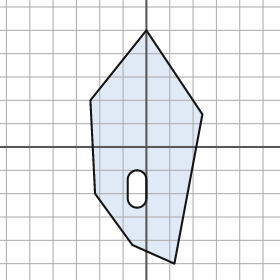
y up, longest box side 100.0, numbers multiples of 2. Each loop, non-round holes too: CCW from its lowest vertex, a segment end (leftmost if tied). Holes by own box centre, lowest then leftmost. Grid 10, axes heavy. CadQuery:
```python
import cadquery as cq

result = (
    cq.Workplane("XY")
    .moveTo(12.0, -50.0)
    .lineTo(24.0, 14.0)
    .lineTo(0.0, 50.0)
    .lineTo(-24.0, 20.0)
    .lineTo(-22.0, -20.0)
    .lineTo(-6.0, -42.0)
    .close()
    .moveTo(-8.0, -22.0)
    .threePointArc((-4.0, -26.0), (0.0, -22.0))
    .lineTo(0.0, -14.0)
    .threePointArc((-4.0, -10.0), (-8.0, -14.0))
    .close()
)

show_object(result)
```